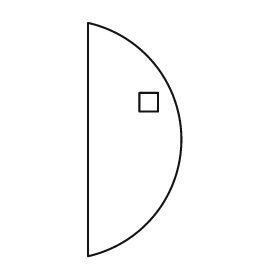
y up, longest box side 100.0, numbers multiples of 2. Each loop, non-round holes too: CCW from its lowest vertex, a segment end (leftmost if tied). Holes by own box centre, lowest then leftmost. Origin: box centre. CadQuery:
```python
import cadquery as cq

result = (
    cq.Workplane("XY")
    .moveTo(-20.0, -50.0)
    .threePointArc((20.0, 0.0), (-20.0, 50.0))
    .close()
    .moveTo(2.0, 12.0)
    .lineTo(10.0, 12.0)
    .lineTo(10.0, 20.0)
    .lineTo(2.0, 20.0)
    .close()
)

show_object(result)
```